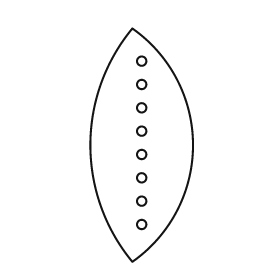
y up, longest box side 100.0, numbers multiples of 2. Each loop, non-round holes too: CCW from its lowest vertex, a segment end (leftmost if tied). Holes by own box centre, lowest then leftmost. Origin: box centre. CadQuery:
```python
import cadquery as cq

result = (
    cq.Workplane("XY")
    .moveTo(-4.0, -50.0)
    .threePointArc((22.0, 0.0), (-4.0, 50.0))
    .threePointArc((-22.0, 0.0), (-4.0, -50.0))
    .close()
    .moveTo(0.0, -34.0)
    .circle(2.0)
    .moveTo(0.0, -24.0)
    .circle(2.0)
    .moveTo(0.0, -14.0)
    .circle(2.0)
    .moveTo(0.0, -4.0)
    .circle(2.0)
    .moveTo(0.0, 6.0)
    .circle(2.0)
    .moveTo(0.0, 16.0)
    .circle(2.0)
    .moveTo(0.0, 26.0)
    .circle(2.0)
    .moveTo(0.0, 36.0)
    .circle(2.0)
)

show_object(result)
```